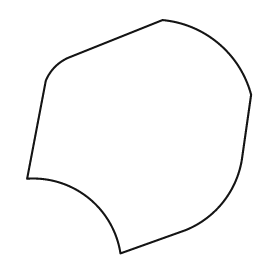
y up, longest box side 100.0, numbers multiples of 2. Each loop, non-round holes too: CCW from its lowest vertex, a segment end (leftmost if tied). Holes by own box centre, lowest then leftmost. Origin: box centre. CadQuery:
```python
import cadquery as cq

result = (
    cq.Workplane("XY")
    .moveTo(-8.0, -50.0)
    .lineTo(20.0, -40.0)
    .threePointArc((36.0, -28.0), (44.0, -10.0))
    .lineTo(48.0, 18.0)
    .threePointArc((34.0, 40.0), (10.0, 50.0))
    .lineTo(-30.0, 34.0)
    .threePointArc((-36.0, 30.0), (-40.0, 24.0))
    .lineTo(-48.0, -18.0)
    .threePointArc((-22.0, -26.0), (-8.0, -50.0))
    .close()
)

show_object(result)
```